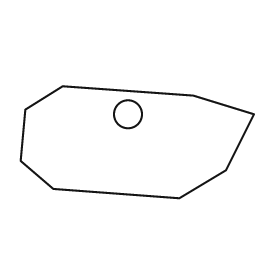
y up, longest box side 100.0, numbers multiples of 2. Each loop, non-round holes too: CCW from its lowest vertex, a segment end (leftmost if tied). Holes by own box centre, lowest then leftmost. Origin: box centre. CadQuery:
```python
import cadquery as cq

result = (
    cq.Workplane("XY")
    .moveTo(18.0, -24.0)
    .lineTo(38.0, -12.0)
    .lineTo(50.0, 12.0)
    .lineTo(24.0, 20.0)
    .lineTo(-32.0, 24.0)
    .lineTo(-48.0, 14.0)
    .lineTo(-50.0, -8.0)
    .lineTo(-36.0, -20.0)
    .close()
    .moveTo(-4.0, 12.0)
    .circle(6.0)
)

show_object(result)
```